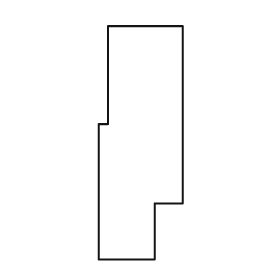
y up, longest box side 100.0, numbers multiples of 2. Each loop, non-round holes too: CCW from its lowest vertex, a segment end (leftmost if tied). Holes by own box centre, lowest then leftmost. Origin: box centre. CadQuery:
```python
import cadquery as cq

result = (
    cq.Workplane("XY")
    .moveTo(-18.0, -50.0)
    .lineTo(6.0, -50.0)
    .lineTo(6.0, -26.0)
    .lineTo(18.0, -26.0)
    .lineTo(18.0, 50.0)
    .lineTo(-14.0, 50.0)
    .lineTo(-14.0, 8.0)
    .lineTo(-18.0, 8.0)
    .close()
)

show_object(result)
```